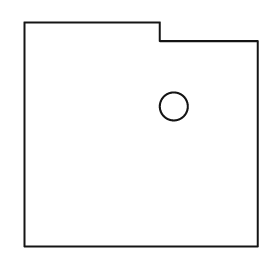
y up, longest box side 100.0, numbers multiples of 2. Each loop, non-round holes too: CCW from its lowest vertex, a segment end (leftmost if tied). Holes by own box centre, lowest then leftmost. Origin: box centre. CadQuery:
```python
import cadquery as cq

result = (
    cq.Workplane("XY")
    .moveTo(-50.0, -48.0)
    .lineTo(50.0, -48.0)
    .lineTo(50.0, 40.0)
    .lineTo(8.0, 40.0)
    .lineTo(8.0, 48.0)
    .lineTo(-50.0, 48.0)
    .close()
    .moveTo(14.0, 12.0)
    .circle(6.0)
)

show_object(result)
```